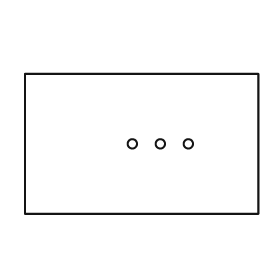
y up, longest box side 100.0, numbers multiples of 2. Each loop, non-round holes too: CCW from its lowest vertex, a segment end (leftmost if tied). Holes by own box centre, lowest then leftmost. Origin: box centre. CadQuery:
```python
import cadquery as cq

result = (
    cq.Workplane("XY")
    .moveTo(-50.0, -30.0)
    .lineTo(50.0, -30.0)
    .lineTo(50.0, 30.0)
    .lineTo(-50.0, 30.0)
    .close()
    .moveTo(-4.0, 0.0)
    .circle(2.0)
    .moveTo(8.0, 0.0)
    .circle(2.0)
    .moveTo(20.0, 0.0)
    .circle(2.0)
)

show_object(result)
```